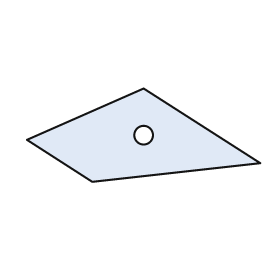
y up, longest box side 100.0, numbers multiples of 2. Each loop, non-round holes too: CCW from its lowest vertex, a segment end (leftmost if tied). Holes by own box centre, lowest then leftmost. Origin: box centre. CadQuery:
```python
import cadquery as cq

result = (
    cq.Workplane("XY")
    .moveTo(-22.0, -20.0)
    .lineTo(50.0, -12.0)
    .lineTo(0.0, 20.0)
    .lineTo(-50.0, -2.0)
    .close()
    .moveTo(0.0, 0.0)
    .circle(4.0)
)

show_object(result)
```